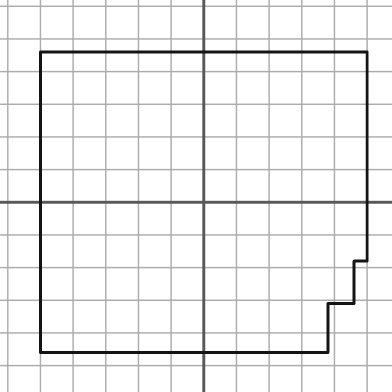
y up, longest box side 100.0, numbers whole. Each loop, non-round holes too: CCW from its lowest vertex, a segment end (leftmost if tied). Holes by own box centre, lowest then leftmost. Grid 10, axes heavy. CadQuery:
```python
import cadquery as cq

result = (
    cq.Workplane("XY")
    .moveTo(-50.0, -46.0)
    .lineTo(38.0, -46.0)
    .lineTo(38.0, -31.0)
    .lineTo(46.0, -31.0)
    .lineTo(46.0, -18.0)
    .lineTo(50.0, -18.0)
    .lineTo(50.0, 46.0)
    .lineTo(-50.0, 46.0)
    .close()
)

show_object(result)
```